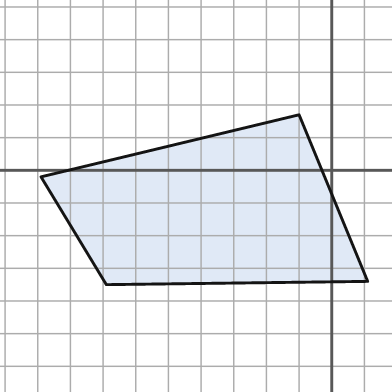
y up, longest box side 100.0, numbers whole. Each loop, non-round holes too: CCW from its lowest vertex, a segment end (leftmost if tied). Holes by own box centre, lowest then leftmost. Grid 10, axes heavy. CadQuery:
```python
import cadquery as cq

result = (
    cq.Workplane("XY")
    .moveTo(-69.0, -35.0)
    .lineTo(11.0, -34.0)
    .lineTo(-10.0, 17.0)
    .lineTo(-89.0, -2.0)
    .close()
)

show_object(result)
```